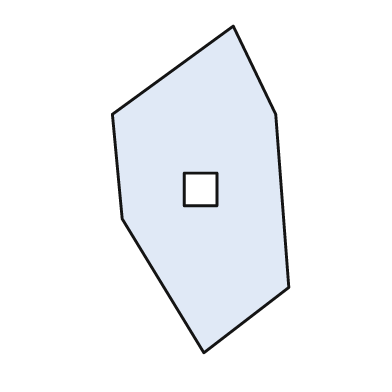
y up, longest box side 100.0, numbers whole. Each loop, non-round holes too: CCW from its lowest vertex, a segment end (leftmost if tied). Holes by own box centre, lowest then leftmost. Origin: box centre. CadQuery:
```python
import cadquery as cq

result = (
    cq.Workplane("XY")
    .moveTo(1.0, -50.0)
    .lineTo(27.0, -30.0)
    .lineTo(23.0, 23.0)
    .lineTo(10.0, 50.0)
    .lineTo(-27.0, 23.0)
    .lineTo(-24.0, -9.0)
    .close()
    .moveTo(-5.0, -5.0)
    .lineTo(5.0, -5.0)
    .lineTo(5.0, 5.0)
    .lineTo(-5.0, 5.0)
    .close()
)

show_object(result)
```